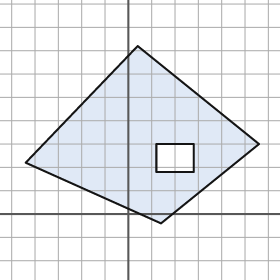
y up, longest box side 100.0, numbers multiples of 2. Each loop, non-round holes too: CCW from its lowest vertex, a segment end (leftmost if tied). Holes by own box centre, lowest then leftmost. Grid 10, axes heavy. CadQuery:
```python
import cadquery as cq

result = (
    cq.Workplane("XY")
    .moveTo(14.0, -4.0)
    .lineTo(56.0, 30.0)
    .lineTo(4.0, 72.0)
    .lineTo(-44.0, 22.0)
    .close()
    .moveTo(12.0, 18.0)
    .lineTo(28.0, 18.0)
    .lineTo(28.0, 30.0)
    .lineTo(12.0, 30.0)
    .close()
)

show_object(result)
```